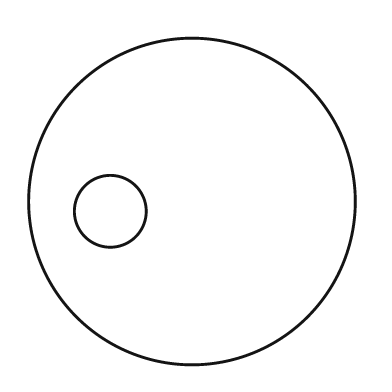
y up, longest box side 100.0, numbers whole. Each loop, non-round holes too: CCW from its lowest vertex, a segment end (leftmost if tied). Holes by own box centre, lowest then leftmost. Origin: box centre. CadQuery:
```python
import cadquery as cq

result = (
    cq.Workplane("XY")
    .moveTo(0.0, 0.0)
    .circle(50.0)
    .moveTo(-25.0, -3.0)
    .circle(11.0)
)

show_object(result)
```